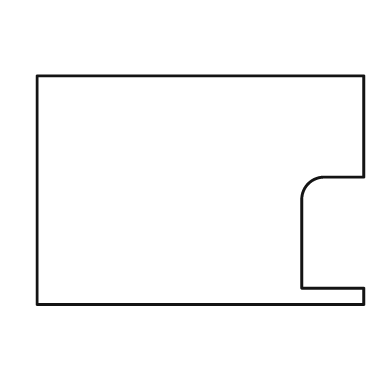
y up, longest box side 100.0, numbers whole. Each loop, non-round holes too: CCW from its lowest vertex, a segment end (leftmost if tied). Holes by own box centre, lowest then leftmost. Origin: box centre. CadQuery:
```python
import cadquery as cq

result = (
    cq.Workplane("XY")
    .moveTo(-50.0, -35.0)
    .lineTo(50.0, -35.0)
    .lineTo(50.0, -30.0)
    .lineTo(31.0, -30.0)
    .lineTo(31.0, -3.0)
    .threePointArc((33.0, 2.0), (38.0, 4.0))
    .lineTo(50.0, 4.0)
    .lineTo(50.0, 35.0)
    .lineTo(-50.0, 35.0)
    .close()
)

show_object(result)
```